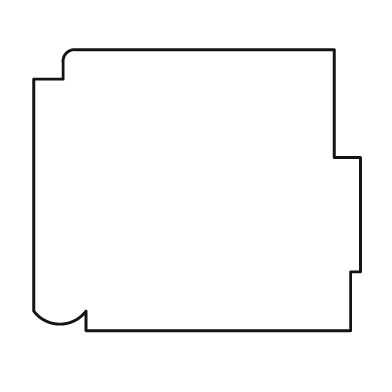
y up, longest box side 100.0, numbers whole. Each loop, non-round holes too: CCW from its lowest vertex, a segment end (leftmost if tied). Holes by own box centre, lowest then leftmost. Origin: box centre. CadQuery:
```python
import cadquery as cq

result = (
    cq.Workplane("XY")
    .moveTo(-34.0, -43.0)
    .lineTo(47.0, -43.0)
    .lineTo(47.0, -25.0)
    .lineTo(50.0, -25.0)
    .lineTo(50.0, 10.0)
    .lineTo(42.0, 10.0)
    .lineTo(42.0, 43.0)
    .lineTo(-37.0, 43.0)
    .threePointArc((-40.0, 42.0), (-41.0, 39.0))
    .lineTo(-41.0, 34.0)
    .lineTo(-50.0, 34.0)
    .lineTo(-50.0, -37.0)
    .threePointArc((-42.0, -41.0), (-34.0, -37.0))
    .close()
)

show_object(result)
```